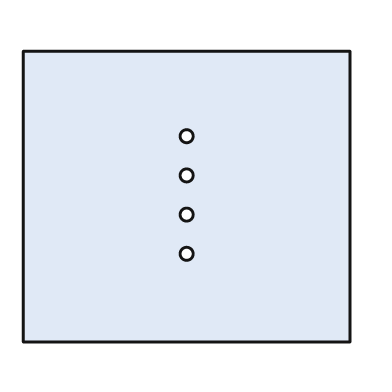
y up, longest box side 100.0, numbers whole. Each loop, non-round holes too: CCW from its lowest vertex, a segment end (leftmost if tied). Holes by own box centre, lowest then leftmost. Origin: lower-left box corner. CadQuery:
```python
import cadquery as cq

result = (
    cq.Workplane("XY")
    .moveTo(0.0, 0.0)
    .lineTo(100.0, 0.0)
    .lineTo(100.0, 89.0)
    .lineTo(0.0, 89.0)
    .close()
    .moveTo(50.0, 27.0)
    .circle(2.0)
    .moveTo(50.0, 39.0)
    .circle(2.0)
    .moveTo(50.0, 51.0)
    .circle(2.0)
    .moveTo(50.0, 63.0)
    .circle(2.0)
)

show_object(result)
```